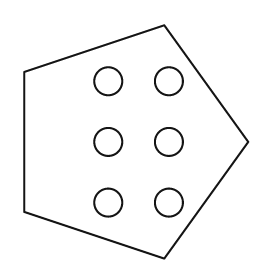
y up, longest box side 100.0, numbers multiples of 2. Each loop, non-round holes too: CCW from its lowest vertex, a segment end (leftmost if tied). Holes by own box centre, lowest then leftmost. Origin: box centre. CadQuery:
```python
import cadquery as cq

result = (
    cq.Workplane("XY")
    .moveTo(12.0, -50.0)
    .lineTo(48.0, 0.0)
    .lineTo(12.0, 50.0)
    .lineTo(-48.0, 30.0)
    .lineTo(-48.0, -30.0)
    .close()
    .moveTo(-12.0, -26.0)
    .circle(6.0)
    .moveTo(14.0, -26.0)
    .circle(6.0)
    .moveTo(-12.0, 0.0)
    .circle(6.0)
    .moveTo(14.0, 0.0)
    .circle(6.0)
    .moveTo(-12.0, 26.0)
    .circle(6.0)
    .moveTo(14.0, 26.0)
    .circle(6.0)
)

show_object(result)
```